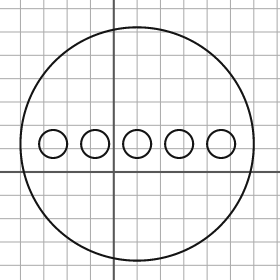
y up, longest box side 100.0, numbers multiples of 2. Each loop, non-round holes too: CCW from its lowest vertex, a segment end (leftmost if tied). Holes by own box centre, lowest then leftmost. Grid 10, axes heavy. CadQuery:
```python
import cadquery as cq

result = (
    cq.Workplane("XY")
    .moveTo(10.0, 12.0)
    .circle(50.0)
    .moveTo(-26.0, 12.0)
    .circle(6.0)
    .moveTo(-8.0, 12.0)
    .circle(6.0)
    .moveTo(10.0, 12.0)
    .circle(6.0)
    .moveTo(28.0, 12.0)
    .circle(6.0)
    .moveTo(46.0, 12.0)
    .circle(6.0)
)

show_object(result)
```